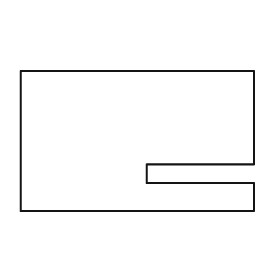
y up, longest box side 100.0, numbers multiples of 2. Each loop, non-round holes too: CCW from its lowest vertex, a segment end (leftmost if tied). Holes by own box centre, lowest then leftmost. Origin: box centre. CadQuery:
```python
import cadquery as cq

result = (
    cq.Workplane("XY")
    .moveTo(-50.0, -30.0)
    .lineTo(50.0, -30.0)
    .lineTo(50.0, -18.0)
    .lineTo(4.0, -18.0)
    .lineTo(4.0, -10.0)
    .lineTo(50.0, -10.0)
    .lineTo(50.0, 30.0)
    .lineTo(-50.0, 30.0)
    .close()
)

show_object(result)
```